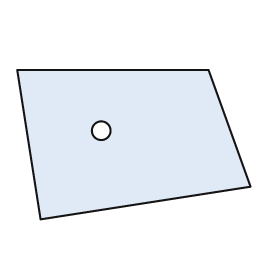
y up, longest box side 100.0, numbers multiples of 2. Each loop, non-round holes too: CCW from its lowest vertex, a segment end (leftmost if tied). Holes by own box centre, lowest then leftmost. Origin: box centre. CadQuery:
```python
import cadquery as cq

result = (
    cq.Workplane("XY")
    .moveTo(-40.0, -32.0)
    .lineTo(50.0, -18.0)
    .lineTo(32.0, 32.0)
    .lineTo(-50.0, 32.0)
    .close()
    .moveTo(-14.0, 6.0)
    .circle(4.0)
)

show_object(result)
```